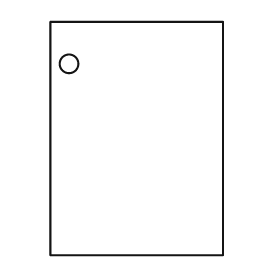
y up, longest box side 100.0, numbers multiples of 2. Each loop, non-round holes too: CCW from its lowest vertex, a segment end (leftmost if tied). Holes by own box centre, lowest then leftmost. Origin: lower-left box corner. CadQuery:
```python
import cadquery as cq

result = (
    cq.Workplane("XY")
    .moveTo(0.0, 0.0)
    .lineTo(74.0, 0.0)
    .lineTo(74.0, 100.0)
    .lineTo(0.0, 100.0)
    .close()
    .moveTo(8.0, 82.0)
    .circle(4.0)
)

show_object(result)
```